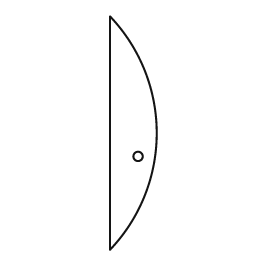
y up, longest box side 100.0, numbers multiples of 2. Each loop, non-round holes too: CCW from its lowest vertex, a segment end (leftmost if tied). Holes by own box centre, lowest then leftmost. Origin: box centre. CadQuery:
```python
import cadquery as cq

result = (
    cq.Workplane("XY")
    .moveTo(-10.0, -50.0)
    .threePointArc((10.0, 0.0), (-10.0, 50.0))
    .close()
    .moveTo(2.0, -10.0)
    .circle(2.0)
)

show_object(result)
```